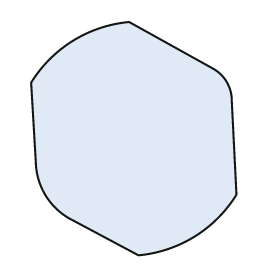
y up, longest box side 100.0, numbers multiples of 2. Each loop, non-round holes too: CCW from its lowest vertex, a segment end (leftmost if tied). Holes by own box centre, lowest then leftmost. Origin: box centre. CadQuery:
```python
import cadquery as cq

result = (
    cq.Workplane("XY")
    .moveTo(2.0, -50.0)
    .threePointArc((26.0, -42.0), (44.0, -24.0))
    .lineTo(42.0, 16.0)
    .threePointArc((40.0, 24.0), (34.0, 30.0))
    .lineTo(-2.0, 50.0)
    .threePointArc((-26.0, 42.0), (-44.0, 24.0))
    .lineTo(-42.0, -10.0)
    .threePointArc((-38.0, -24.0), (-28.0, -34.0))
    .close()
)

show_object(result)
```